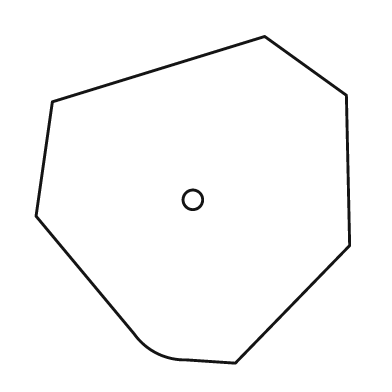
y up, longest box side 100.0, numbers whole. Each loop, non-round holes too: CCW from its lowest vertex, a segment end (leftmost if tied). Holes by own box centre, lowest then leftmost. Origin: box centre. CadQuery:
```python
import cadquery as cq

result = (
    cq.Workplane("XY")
    .moveTo(13.0, -50.0)
    .lineTo(48.0, -14.0)
    .lineTo(47.0, 32.0)
    .lineTo(22.0, 50.0)
    .lineTo(-43.0, 30.0)
    .lineTo(-48.0, -5.0)
    .lineTo(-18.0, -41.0)
    .threePointArc((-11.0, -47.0), (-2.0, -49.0))
    .close()
    .moveTo(0.0, 0.0)
    .circle(3.0)
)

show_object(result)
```